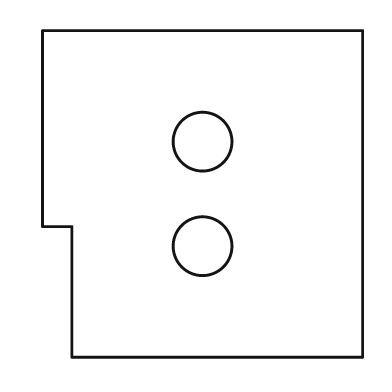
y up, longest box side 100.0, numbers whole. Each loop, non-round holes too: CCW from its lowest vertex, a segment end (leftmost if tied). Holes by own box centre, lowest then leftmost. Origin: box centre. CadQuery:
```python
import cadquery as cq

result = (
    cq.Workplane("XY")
    .moveTo(-40.0, -50.0)
    .lineTo(49.0, -50.0)
    .lineTo(49.0, 50.0)
    .lineTo(-49.0, 50.0)
    .lineTo(-49.0, -10.0)
    .lineTo(-40.0, -10.0)
    .close()
    .moveTo(0.0, -16.0)
    .circle(9.0)
    .moveTo(0.0, 16.0)
    .circle(9.0)
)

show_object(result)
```